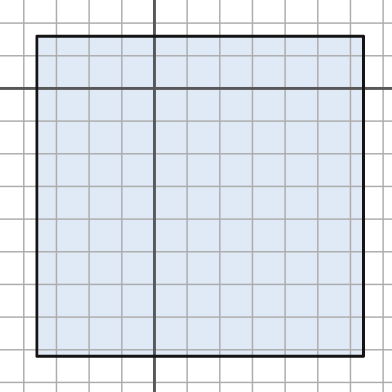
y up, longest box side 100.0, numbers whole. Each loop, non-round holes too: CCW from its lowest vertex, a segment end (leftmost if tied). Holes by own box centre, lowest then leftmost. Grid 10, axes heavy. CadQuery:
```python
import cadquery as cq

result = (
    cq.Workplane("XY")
    .moveTo(-36.0, -82.0)
    .lineTo(64.0, -82.0)
    .lineTo(64.0, 16.0)
    .lineTo(-36.0, 16.0)
    .close()
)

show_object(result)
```